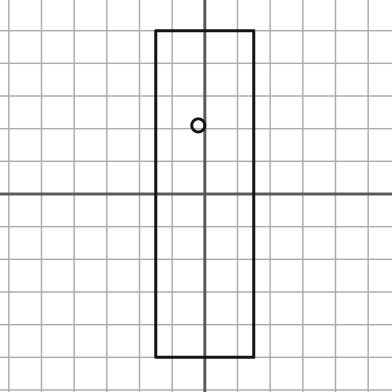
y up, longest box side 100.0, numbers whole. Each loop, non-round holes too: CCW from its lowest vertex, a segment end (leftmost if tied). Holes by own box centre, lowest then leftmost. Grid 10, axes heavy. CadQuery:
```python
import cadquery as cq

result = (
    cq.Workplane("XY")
    .moveTo(-15.0, -50.0)
    .lineTo(15.0, -50.0)
    .lineTo(15.0, 50.0)
    .lineTo(-15.0, 50.0)
    .close()
    .moveTo(-2.0, 21.0)
    .circle(2.0)
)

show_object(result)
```